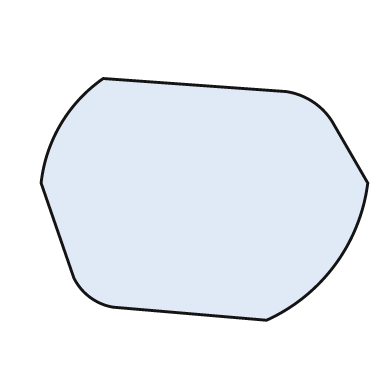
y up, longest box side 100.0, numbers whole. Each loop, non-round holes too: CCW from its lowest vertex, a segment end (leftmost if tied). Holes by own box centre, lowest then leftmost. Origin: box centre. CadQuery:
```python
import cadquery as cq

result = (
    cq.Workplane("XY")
    .moveTo(19.0, -37.0)
    .threePointArc((40.0, -20.0), (50.0, 5.0))
    .lineTo(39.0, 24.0)
    .threePointArc((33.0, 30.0), (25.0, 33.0))
    .lineTo(-31.0, 37.0)
    .threePointArc((-44.0, 23.0), (-50.0, 5.0))
    .lineTo(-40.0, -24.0)
    .threePointArc((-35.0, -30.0), (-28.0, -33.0))
    .close()
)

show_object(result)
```